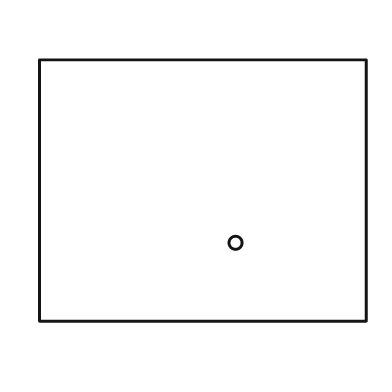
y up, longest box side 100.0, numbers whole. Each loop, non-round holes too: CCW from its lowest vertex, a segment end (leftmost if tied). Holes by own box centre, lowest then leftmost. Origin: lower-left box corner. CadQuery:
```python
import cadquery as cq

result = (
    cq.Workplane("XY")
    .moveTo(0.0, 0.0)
    .lineTo(100.0, 0.0)
    .lineTo(100.0, 80.0)
    .lineTo(0.0, 80.0)
    .close()
    .moveTo(60.0, 24.0)
    .circle(2.0)
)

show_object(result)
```